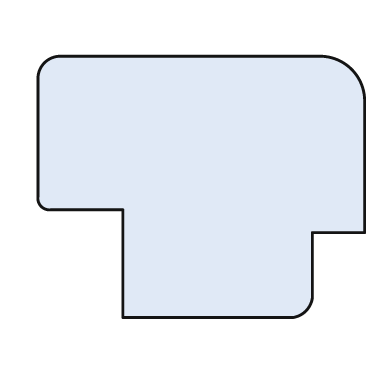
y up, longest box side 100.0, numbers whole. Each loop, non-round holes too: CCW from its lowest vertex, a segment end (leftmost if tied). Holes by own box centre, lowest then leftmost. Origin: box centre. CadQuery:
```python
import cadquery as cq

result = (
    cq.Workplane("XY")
    .moveTo(-24.0, -40.0)
    .lineTo(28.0, -40.0)
    .threePointArc((32.0, -38.0), (34.0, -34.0))
    .lineTo(34.0, -14.0)
    .lineTo(50.0, -14.0)
    .lineTo(50.0, 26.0)
    .threePointArc((46.0, 36.0), (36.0, 40.0))
    .lineTo(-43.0, 40.0)
    .threePointArc((-48.0, 38.0), (-50.0, 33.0))
    .lineTo(-50.0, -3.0)
    .threePointArc((-49.0, -6.0), (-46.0, -7.0))
    .lineTo(-24.0, -7.0)
    .close()
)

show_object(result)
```